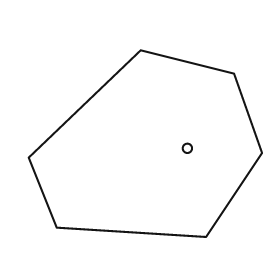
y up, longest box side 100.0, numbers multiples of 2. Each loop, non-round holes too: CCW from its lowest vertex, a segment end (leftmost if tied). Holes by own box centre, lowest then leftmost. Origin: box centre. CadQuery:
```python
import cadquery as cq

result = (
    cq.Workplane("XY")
    .moveTo(26.0, -40.0)
    .lineTo(50.0, -4.0)
    .lineTo(38.0, 30.0)
    .lineTo(-2.0, 40.0)
    .lineTo(-50.0, -6.0)
    .lineTo(-38.0, -36.0)
    .close()
    .moveTo(18.0, -2.0)
    .circle(2.0)
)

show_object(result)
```